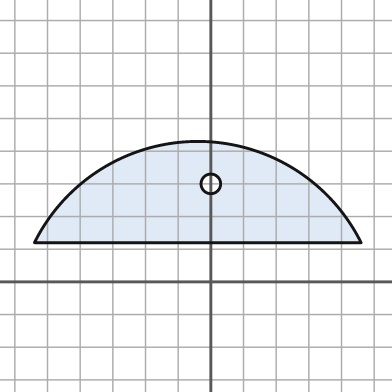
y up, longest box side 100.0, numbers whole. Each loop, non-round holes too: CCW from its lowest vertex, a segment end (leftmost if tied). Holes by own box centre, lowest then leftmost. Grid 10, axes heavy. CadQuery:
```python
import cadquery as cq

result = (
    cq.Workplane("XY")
    .moveTo(-54.0, 12.0)
    .lineTo(46.0, 12.0)
    .threePointArc((-4.0, 43.0), (-54.0, 12.0))
    .close()
    .moveTo(0.0, 30.0)
    .circle(3.0)
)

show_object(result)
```